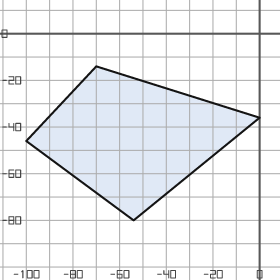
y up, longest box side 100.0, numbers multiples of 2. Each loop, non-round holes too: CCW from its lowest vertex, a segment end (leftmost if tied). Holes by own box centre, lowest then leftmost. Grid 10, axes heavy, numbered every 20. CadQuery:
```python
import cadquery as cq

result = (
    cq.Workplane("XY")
    .moveTo(-54.0, -80.0)
    .lineTo(0.0, -36.0)
    .lineTo(-70.0, -14.0)
    .lineTo(-100.0, -46.0)
    .close()
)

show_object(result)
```